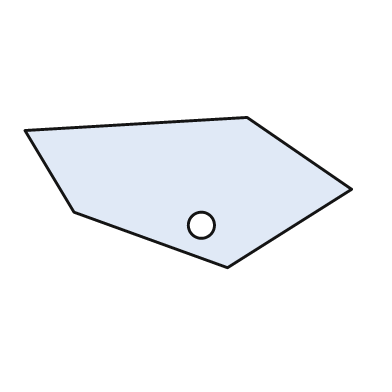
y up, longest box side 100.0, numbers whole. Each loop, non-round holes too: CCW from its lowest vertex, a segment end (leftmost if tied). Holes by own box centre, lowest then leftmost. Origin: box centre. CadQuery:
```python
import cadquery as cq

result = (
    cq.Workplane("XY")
    .moveTo(12.0, -23.0)
    .lineTo(50.0, 1.0)
    .lineTo(18.0, 23.0)
    .lineTo(-50.0, 19.0)
    .lineTo(-35.0, -6.0)
    .close()
    .moveTo(4.0, -10.0)
    .circle(4.0)
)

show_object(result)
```